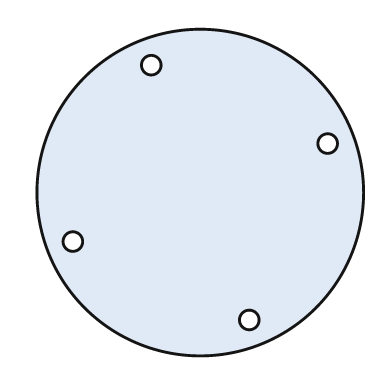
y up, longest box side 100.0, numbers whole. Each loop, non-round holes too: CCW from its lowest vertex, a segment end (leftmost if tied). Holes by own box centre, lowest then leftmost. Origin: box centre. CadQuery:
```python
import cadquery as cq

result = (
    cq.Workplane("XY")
    .moveTo(0.0, 0.0)
    .circle(50.0)
    .moveTo(15.0, -39.0)
    .circle(3.0)
    .moveTo(-39.0, -15.0)
    .circle(3.0)
    .moveTo(39.0, 15.0)
    .circle(3.0)
    .moveTo(-15.0, 39.0)
    .circle(3.0)
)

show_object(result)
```